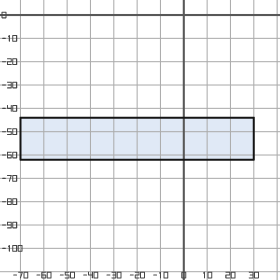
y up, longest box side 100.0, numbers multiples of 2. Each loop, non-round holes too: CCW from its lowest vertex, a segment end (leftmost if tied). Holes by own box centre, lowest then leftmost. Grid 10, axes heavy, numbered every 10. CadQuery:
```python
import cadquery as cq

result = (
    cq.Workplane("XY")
    .moveTo(-70.0, -62.0)
    .lineTo(30.0, -62.0)
    .lineTo(30.0, -44.0)
    .lineTo(-70.0, -44.0)
    .close()
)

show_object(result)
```